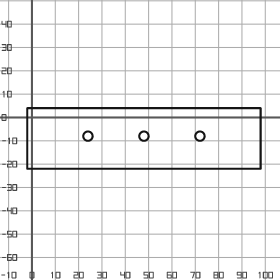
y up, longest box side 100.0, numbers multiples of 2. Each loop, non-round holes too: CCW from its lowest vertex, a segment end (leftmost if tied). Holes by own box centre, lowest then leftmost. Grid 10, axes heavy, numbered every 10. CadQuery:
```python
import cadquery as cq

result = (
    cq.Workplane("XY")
    .moveTo(-2.0, -22.0)
    .lineTo(98.0, -22.0)
    .lineTo(98.0, 4.0)
    .lineTo(-2.0, 4.0)
    .close()
    .moveTo(24.0, -8.0)
    .circle(2.0)
    .moveTo(48.0, -8.0)
    .circle(2.0)
    .moveTo(72.0, -8.0)
    .circle(2.0)
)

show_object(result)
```